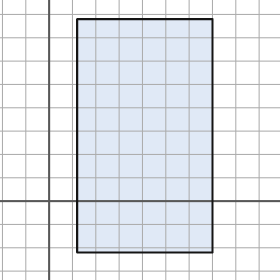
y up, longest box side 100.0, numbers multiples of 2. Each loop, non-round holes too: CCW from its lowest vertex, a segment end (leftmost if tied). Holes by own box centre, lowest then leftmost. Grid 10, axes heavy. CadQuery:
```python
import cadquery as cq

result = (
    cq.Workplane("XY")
    .moveTo(12.0, -22.0)
    .lineTo(70.0, -22.0)
    .lineTo(70.0, 78.0)
    .lineTo(12.0, 78.0)
    .close()
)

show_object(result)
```